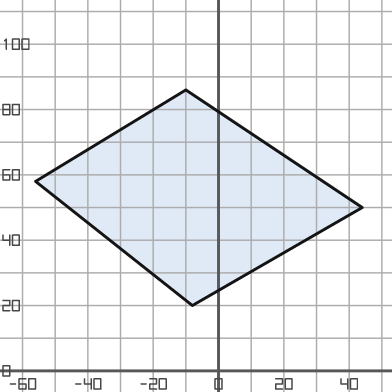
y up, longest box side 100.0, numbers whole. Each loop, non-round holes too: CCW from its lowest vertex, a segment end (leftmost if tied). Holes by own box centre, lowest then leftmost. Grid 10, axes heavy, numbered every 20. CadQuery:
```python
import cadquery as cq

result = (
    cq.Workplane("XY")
    .moveTo(-8.0, 20.0)
    .lineTo(44.0, 50.0)
    .lineTo(-10.0, 86.0)
    .lineTo(-56.0, 58.0)
    .close()
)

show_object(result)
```